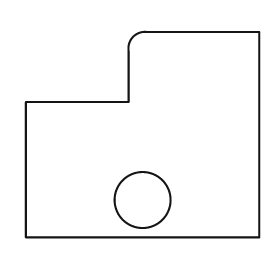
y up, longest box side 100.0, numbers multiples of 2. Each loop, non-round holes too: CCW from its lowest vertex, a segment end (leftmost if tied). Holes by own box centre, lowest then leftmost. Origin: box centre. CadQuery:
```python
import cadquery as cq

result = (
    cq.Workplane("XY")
    .moveTo(-50.0, -44.0)
    .lineTo(50.0, -44.0)
    .lineTo(50.0, 44.0)
    .lineTo(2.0, 44.0)
    .threePointArc((-4.0, 42.0), (-6.0, 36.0))
    .lineTo(-6.0, 14.0)
    .lineTo(-50.0, 14.0)
    .close()
    .moveTo(0.0, -28.0)
    .circle(12.0)
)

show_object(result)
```